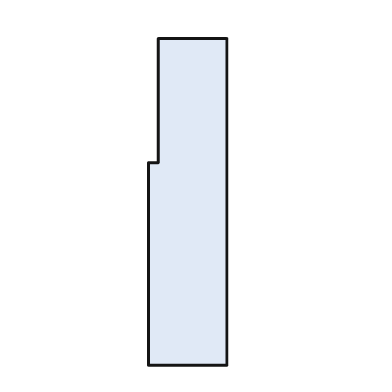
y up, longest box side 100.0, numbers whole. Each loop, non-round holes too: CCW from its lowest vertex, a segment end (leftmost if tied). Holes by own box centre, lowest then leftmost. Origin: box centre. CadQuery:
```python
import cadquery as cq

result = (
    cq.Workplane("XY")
    .moveTo(-12.0, -50.0)
    .lineTo(12.0, -50.0)
    .lineTo(12.0, 50.0)
    .lineTo(-9.0, 50.0)
    .lineTo(-9.0, 12.0)
    .lineTo(-12.0, 12.0)
    .close()
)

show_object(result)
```